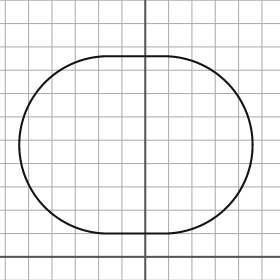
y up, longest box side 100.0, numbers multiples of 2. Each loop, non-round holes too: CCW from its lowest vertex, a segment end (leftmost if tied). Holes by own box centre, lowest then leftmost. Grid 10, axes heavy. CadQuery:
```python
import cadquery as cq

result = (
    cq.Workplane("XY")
    .moveTo(-16.0, 10.0)
    .lineTo(8.0, 10.0)
    .threePointArc((46.0, 48.0), (8.0, 86.0))
    .lineTo(-16.0, 86.0)
    .threePointArc((-54.0, 48.0), (-16.0, 10.0))
    .close()
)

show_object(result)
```